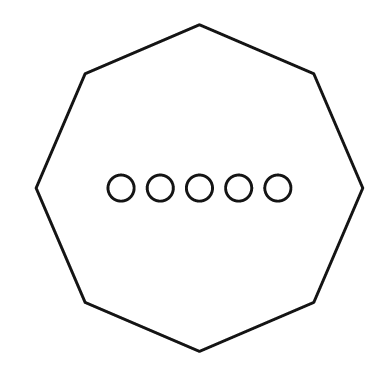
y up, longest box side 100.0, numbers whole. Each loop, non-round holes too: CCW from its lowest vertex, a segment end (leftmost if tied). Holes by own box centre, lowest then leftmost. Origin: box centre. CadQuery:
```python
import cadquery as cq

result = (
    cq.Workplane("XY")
    .moveTo(0.0, -50.0)
    .lineTo(35.0, -35.0)
    .lineTo(50.0, 0.0)
    .lineTo(35.0, 35.0)
    .lineTo(0.0, 50.0)
    .lineTo(-35.0, 35.0)
    .lineTo(-50.0, 0.0)
    .lineTo(-35.0, -35.0)
    .close()
    .moveTo(-24.0, 0.0)
    .circle(4.0)
    .moveTo(-12.0, 0.0)
    .circle(4.0)
    .moveTo(0.0, 0.0)
    .circle(4.0)
    .moveTo(12.0, 0.0)
    .circle(4.0)
    .moveTo(24.0, 0.0)
    .circle(4.0)
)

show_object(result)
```